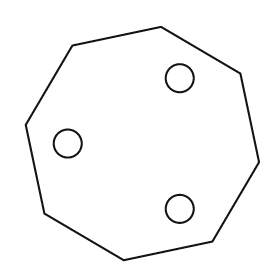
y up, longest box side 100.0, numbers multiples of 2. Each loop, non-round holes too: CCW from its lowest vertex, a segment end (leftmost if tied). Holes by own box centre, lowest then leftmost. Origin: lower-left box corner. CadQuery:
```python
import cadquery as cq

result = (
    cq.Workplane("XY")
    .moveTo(42.0, 0.0)
    .lineTo(80.0, 8.0)
    .lineTo(100.0, 42.0)
    .lineTo(92.0, 80.0)
    .lineTo(58.0, 100.0)
    .lineTo(20.0, 92.0)
    .lineTo(0.0, 58.0)
    .lineTo(8.0, 20.0)
    .close()
    .moveTo(66.0, 22.0)
    .circle(6.0)
    .moveTo(18.0, 50.0)
    .circle(6.0)
    .moveTo(66.0, 78.0)
    .circle(6.0)
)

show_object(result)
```